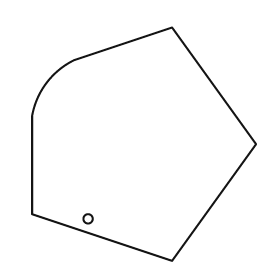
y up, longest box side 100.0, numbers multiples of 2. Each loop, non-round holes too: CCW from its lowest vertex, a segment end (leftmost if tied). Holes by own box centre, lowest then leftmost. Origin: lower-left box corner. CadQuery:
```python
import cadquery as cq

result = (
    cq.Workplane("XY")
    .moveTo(60.0, 0.0)
    .lineTo(96.0, 50.0)
    .lineTo(60.0, 100.0)
    .lineTo(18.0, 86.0)
    .threePointArc((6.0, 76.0), (0.0, 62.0))
    .lineTo(0.0, 20.0)
    .close()
    .moveTo(24.0, 18.0)
    .circle(2.0)
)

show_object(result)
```